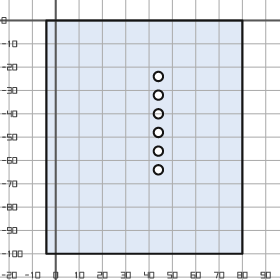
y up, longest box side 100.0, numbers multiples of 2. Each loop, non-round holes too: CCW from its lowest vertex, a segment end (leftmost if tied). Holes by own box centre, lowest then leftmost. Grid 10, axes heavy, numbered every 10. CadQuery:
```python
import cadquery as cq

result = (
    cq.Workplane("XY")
    .moveTo(-4.0, -100.0)
    .lineTo(80.0, -100.0)
    .lineTo(80.0, 0.0)
    .lineTo(-4.0, 0.0)
    .close()
    .moveTo(44.0, -64.0)
    .circle(2.0)
    .moveTo(44.0, -56.0)
    .circle(2.0)
    .moveTo(44.0, -48.0)
    .circle(2.0)
    .moveTo(44.0, -40.0)
    .circle(2.0)
    .moveTo(44.0, -32.0)
    .circle(2.0)
    .moveTo(44.0, -24.0)
    .circle(2.0)
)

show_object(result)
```